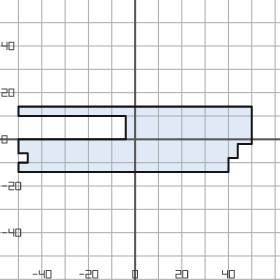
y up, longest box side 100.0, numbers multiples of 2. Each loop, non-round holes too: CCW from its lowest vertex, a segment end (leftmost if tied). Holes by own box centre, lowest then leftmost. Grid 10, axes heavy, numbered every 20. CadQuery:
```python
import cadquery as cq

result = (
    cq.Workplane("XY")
    .moveTo(-50.0, -14.0)
    .lineTo(40.0, -14.0)
    .lineTo(40.0, -8.0)
    .lineTo(44.0, -8.0)
    .lineTo(44.0, -2.0)
    .lineTo(50.0, -2.0)
    .lineTo(50.0, 14.0)
    .lineTo(-50.0, 14.0)
    .lineTo(-50.0, 10.0)
    .lineTo(-4.0, 10.0)
    .lineTo(-4.0, 0.0)
    .lineTo(-50.0, 0.0)
    .lineTo(-50.0, -6.0)
    .lineTo(-46.0, -6.0)
    .lineTo(-46.0, -10.0)
    .lineTo(-50.0, -10.0)
    .close()
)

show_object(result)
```